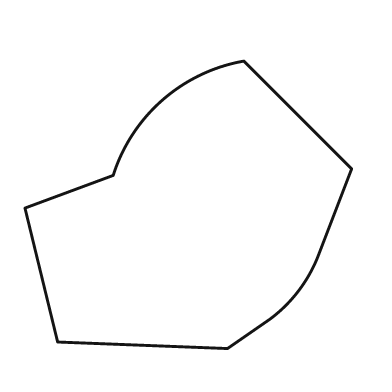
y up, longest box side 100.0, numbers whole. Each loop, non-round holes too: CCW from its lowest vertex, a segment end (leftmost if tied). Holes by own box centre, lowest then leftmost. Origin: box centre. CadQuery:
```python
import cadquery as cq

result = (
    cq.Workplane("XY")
    .moveTo(12.0, -44.0)
    .lineTo(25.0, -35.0)
    .threePointArc((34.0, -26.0), (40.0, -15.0))
    .lineTo(50.0, 11.0)
    .lineTo(17.0, 44.0)
    .threePointArc((-8.0, 32.0), (-23.0, 9.0))
    .lineTo(-50.0, -1.0)
    .lineTo(-40.0, -42.0)
    .close()
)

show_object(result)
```